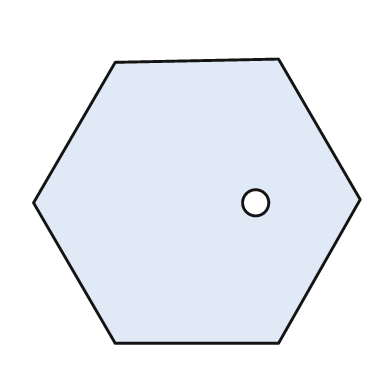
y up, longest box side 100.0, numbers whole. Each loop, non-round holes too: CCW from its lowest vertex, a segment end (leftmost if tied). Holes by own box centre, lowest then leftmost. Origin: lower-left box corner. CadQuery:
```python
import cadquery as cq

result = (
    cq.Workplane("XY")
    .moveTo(25.0, 0.0)
    .lineTo(75.0, 0.0)
    .lineTo(100.0, 44.0)
    .lineTo(75.0, 87.0)
    .lineTo(25.0, 86.0)
    .lineTo(0.0, 43.0)
    .close()
    .moveTo(68.0, 43.0)
    .circle(4.0)
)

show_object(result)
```